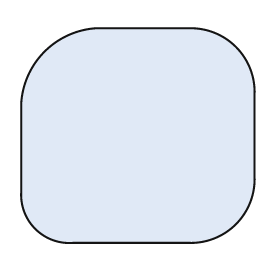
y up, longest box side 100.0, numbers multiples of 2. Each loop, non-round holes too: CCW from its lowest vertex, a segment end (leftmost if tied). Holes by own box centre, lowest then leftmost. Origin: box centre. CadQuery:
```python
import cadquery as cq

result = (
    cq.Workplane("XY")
    .moveTo(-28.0, -46.0)
    .lineTo(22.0, -46.0)
    .threePointArc((42.0, -38.0), (50.0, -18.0))
    .lineTo(50.0, 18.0)
    .threePointArc((42.0, 38.0), (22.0, 46.0))
    .lineTo(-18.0, 46.0)
    .threePointArc((-40.0, 36.0), (-50.0, 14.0))
    .lineTo(-50.0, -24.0)
    .threePointArc((-44.0, -40.0), (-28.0, -46.0))
    .close()
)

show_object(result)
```